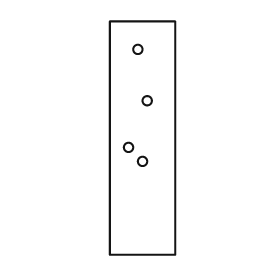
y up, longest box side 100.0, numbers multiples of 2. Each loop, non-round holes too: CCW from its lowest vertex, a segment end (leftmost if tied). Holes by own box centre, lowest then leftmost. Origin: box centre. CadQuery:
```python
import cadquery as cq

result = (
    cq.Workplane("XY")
    .moveTo(-14.0, -50.0)
    .lineTo(14.0, -50.0)
    .lineTo(14.0, 50.0)
    .lineTo(-14.0, 50.0)
    .close()
    .moveTo(0.0, -10.0)
    .circle(2.0)
    .moveTo(-6.0, -4.0)
    .circle(2.0)
    .moveTo(2.0, 16.0)
    .circle(2.0)
    .moveTo(-2.0, 38.0)
    .circle(2.0)
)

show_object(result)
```